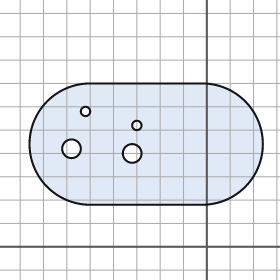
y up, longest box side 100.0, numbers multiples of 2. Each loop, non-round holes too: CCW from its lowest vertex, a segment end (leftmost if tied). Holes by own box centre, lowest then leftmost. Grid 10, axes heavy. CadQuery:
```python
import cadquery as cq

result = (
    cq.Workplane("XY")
    .moveTo(-50.0, 18.0)
    .lineTo(-2.0, 18.0)
    .threePointArc((24.0, 44.0), (-2.0, 70.0))
    .lineTo(-50.0, 70.0)
    .threePointArc((-76.0, 44.0), (-50.0, 18.0))
    .close()
    .moveTo(-32.0, 40.0)
    .circle(4.0)
    .moveTo(-58.0, 42.0)
    .circle(4.0)
    .moveTo(-30.0, 52.0)
    .circle(2.0)
    .moveTo(-52.0, 58.0)
    .circle(2.0)
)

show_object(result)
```